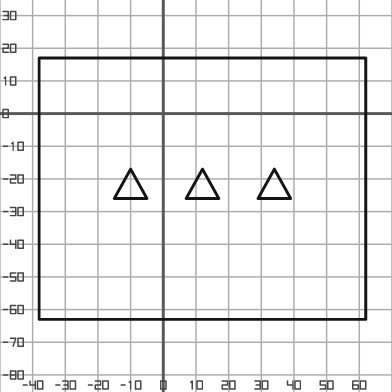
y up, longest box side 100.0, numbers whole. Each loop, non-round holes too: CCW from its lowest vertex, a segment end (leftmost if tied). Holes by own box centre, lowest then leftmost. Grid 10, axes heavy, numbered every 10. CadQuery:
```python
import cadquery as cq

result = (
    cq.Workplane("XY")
    .moveTo(-38.0, -63.0)
    .lineTo(62.0, -63.0)
    .lineTo(62.0, 17.0)
    .lineTo(-38.0, 17.0)
    .close()
    .moveTo(-15.0, -26.0)
    .lineTo(-5.0, -26.0)
    .lineTo(-10.0, -17.0)
    .close()
    .moveTo(7.0, -26.0)
    .lineTo(17.0, -26.0)
    .lineTo(12.0, -17.0)
    .close()
    .moveTo(29.0, -26.0)
    .lineTo(39.0, -26.0)
    .lineTo(34.0, -17.0)
    .close()
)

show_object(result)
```